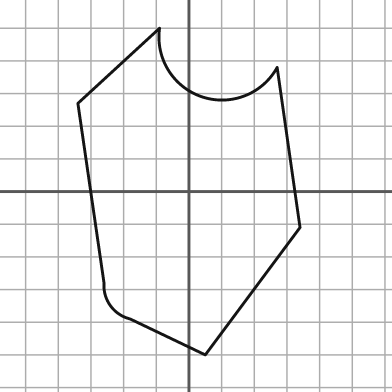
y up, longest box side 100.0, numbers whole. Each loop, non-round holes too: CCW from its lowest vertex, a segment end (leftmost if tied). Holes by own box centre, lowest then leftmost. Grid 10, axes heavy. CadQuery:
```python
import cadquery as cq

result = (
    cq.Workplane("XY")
    .moveTo(5.0, -50.0)
    .lineTo(34.0, -11.0)
    .lineTo(27.0, 38.0)
    .threePointArc((4.0, 29.0), (-9.0, 50.0))
    .lineTo(-34.0, 27.0)
    .lineTo(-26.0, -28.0)
    .threePointArc((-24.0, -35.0), (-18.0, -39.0))
    .close()
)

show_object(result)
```